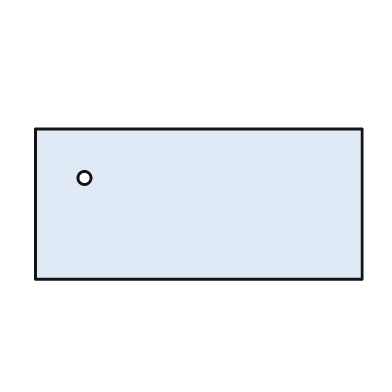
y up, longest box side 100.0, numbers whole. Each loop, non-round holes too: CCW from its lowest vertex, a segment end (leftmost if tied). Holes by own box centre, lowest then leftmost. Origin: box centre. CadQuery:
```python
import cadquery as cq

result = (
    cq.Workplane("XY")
    .moveTo(-50.0, -23.0)
    .lineTo(50.0, -23.0)
    .lineTo(50.0, 23.0)
    .lineTo(-50.0, 23.0)
    .close()
    .moveTo(-35.0, 8.0)
    .circle(2.0)
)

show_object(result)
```